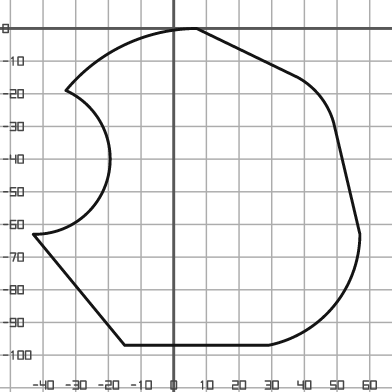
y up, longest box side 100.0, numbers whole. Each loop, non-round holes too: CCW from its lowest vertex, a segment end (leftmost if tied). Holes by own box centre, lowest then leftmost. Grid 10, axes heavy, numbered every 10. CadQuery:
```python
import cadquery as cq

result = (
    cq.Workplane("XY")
    .moveTo(-15.0, -97.0)
    .lineTo(29.0, -97.0)
    .threePointArc((49.0, -85.0), (57.0, -63.0))
    .lineTo(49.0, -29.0)
    .threePointArc((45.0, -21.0), (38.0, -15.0))
    .lineTo(7.0, 0.0)
    .threePointArc((-15.0, -5.0), (-33.0, -19.0))
    .threePointArc((-20.0, -45.0), (-43.0, -63.0))
    .close()
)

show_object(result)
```